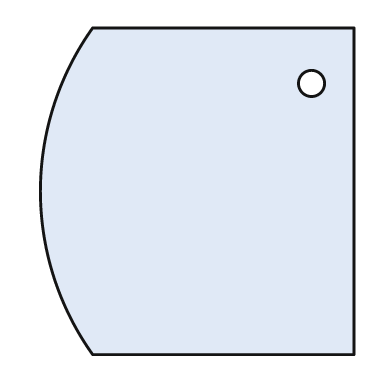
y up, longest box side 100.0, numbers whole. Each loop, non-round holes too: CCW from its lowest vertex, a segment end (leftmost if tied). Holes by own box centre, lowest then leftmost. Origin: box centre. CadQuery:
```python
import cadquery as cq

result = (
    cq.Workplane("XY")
    .moveTo(-32.0, -50.0)
    .lineTo(48.0, -50.0)
    .lineTo(48.0, 50.0)
    .lineTo(-32.0, 50.0)
    .threePointArc((-48.0, 0.0), (-32.0, -50.0))
    .close()
    .moveTo(35.0, 33.0)
    .circle(4.0)
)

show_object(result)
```